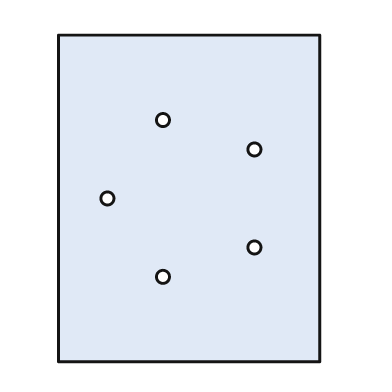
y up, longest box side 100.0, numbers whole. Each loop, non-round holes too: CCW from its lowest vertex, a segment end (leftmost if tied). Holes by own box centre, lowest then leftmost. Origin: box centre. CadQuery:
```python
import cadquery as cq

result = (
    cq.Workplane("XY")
    .moveTo(-40.0, -50.0)
    .lineTo(40.0, -50.0)
    .lineTo(40.0, 50.0)
    .lineTo(-40.0, 50.0)
    .close()
    .moveTo(-8.0, -24.0)
    .circle(2.0)
    .moveTo(20.0, -15.0)
    .circle(2.0)
    .moveTo(-25.0, 0.0)
    .circle(2.0)
    .moveTo(20.0, 15.0)
    .circle(2.0)
    .moveTo(-8.0, 24.0)
    .circle(2.0)
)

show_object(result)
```